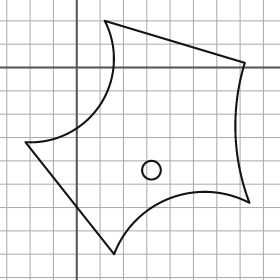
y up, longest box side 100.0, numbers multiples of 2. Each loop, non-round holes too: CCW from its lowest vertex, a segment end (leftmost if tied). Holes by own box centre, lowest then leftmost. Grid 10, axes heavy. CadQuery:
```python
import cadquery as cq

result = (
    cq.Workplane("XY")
    .moveTo(16.0, -80.0)
    .threePointArc((40.0, -56.0), (74.0, -58.0))
    .threePointArc((68.0, -28.0), (72.0, 2.0))
    .lineTo(12.0, 20.0)
    .threePointArc((10.0, -16.0), (-22.0, -32.0))
    .close()
    .moveTo(32.0, -44.0)
    .circle(4.0)
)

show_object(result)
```